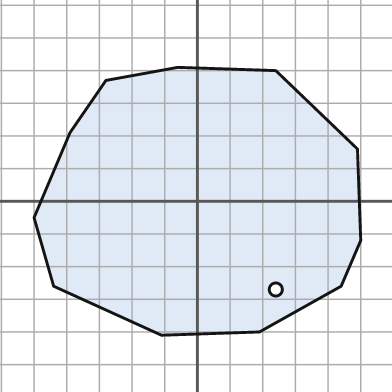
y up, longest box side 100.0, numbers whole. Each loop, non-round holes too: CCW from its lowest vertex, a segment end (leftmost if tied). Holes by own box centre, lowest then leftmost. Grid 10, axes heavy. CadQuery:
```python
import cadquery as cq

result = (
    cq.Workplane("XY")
    .moveTo(-11.0, -41.0)
    .lineTo(19.0, -40.0)
    .lineTo(44.0, -26.0)
    .lineTo(50.0, -12.0)
    .lineTo(49.0, 16.0)
    .lineTo(24.0, 40.0)
    .lineTo(-6.0, 41.0)
    .lineTo(-28.0, 37.0)
    .lineTo(-39.0, 21.0)
    .lineTo(-50.0, -5.0)
    .lineTo(-44.0, -26.0)
    .close()
    .moveTo(24.0, -27.0)
    .circle(2.0)
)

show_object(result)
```